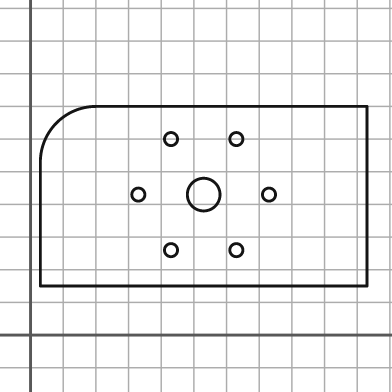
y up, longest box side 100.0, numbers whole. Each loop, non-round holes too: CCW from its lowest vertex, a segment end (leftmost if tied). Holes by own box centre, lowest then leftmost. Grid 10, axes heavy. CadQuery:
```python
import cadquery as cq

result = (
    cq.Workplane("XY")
    .moveTo(3.0, 15.0)
    .lineTo(103.0, 15.0)
    .lineTo(103.0, 70.0)
    .lineTo(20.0, 70.0)
    .threePointArc((8.0, 65.0), (3.0, 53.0))
    .close()
    .moveTo(43.0, 26.0)
    .circle(2.0)
    .moveTo(63.0, 26.0)
    .circle(2.0)
    .moveTo(33.0, 43.0)
    .circle(2.0)
    .moveTo(53.0, 43.0)
    .circle(5.0)
    .moveTo(73.0, 43.0)
    .circle(2.0)
    .moveTo(43.0, 60.0)
    .circle(2.0)
    .moveTo(63.0, 60.0)
    .circle(2.0)
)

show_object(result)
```